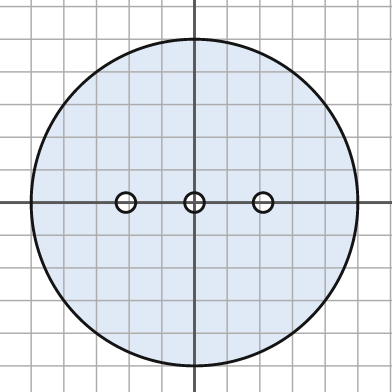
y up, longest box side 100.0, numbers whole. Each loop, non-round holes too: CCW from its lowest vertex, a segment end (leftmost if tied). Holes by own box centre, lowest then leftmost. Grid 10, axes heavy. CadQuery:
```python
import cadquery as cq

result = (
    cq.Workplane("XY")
    .moveTo(0.0, 0.0)
    .circle(50.0)
    .moveTo(-21.0, 0.0)
    .circle(3.0)
    .moveTo(0.0, 0.0)
    .circle(3.0)
    .moveTo(21.0, 0.0)
    .circle(3.0)
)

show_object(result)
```